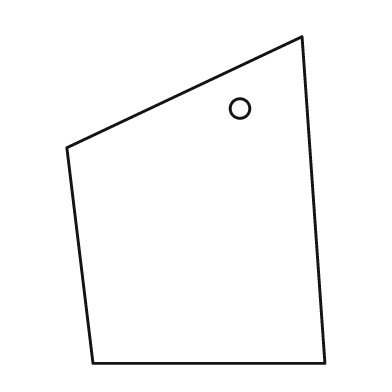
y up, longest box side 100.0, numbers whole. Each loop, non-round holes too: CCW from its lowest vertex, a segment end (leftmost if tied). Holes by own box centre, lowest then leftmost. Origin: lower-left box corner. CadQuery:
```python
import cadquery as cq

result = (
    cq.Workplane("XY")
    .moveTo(8.0, 0.0)
    .lineTo(79.0, 0.0)
    .lineTo(72.0, 100.0)
    .lineTo(0.0, 66.0)
    .close()
    .moveTo(53.0, 78.0)
    .circle(3.0)
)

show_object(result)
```